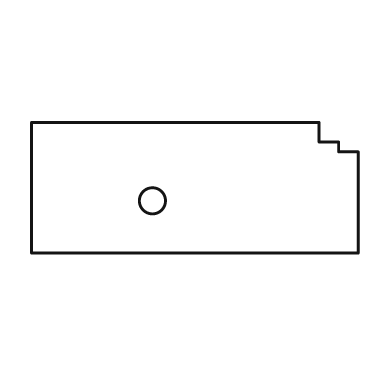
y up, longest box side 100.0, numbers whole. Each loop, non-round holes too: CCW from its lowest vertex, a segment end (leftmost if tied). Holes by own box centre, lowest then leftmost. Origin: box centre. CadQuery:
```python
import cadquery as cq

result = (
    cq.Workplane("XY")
    .moveTo(-50.0, -20.0)
    .lineTo(50.0, -20.0)
    .lineTo(50.0, 11.0)
    .lineTo(44.0, 11.0)
    .lineTo(44.0, 14.0)
    .lineTo(38.0, 14.0)
    .lineTo(38.0, 20.0)
    .lineTo(-50.0, 20.0)
    .close()
    .moveTo(-13.0, -4.0)
    .circle(4.0)
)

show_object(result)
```